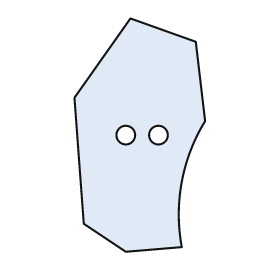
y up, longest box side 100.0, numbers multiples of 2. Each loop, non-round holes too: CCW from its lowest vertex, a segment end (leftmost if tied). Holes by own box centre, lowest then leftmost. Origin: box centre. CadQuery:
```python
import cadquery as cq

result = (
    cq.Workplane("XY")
    .moveTo(-6.0, -50.0)
    .lineTo(18.0, -48.0)
    .threePointArc((18.0, -20.0), (28.0, 6.0))
    .lineTo(24.0, 40.0)
    .lineTo(-4.0, 50.0)
    .lineTo(-28.0, 16.0)
    .lineTo(-24.0, -38.0)
    .close()
    .moveTo(-6.0, 0.0)
    .circle(4.0)
    .moveTo(8.0, 0.0)
    .circle(4.0)
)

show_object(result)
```